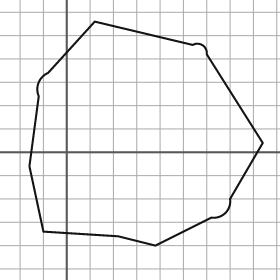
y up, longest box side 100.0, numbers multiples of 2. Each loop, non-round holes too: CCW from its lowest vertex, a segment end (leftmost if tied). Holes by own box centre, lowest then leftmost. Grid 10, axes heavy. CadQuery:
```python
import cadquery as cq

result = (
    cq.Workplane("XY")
    .moveTo(38.0, -40.0)
    .lineTo(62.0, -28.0)
    .threePointArc((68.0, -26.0), (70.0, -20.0))
    .lineTo(84.0, 4.0)
    .lineTo(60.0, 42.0)
    .threePointArc((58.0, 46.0), (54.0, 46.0))
    .lineTo(12.0, 56.0)
    .lineTo(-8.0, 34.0)
    .threePointArc((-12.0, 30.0), (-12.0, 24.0))
    .lineTo(-16.0, -6.0)
    .lineTo(-10.0, -34.0)
    .lineTo(22.0, -36.0)
    .close()
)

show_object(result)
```